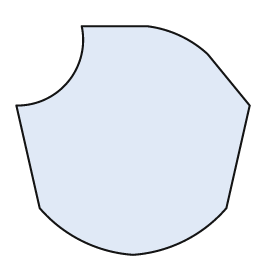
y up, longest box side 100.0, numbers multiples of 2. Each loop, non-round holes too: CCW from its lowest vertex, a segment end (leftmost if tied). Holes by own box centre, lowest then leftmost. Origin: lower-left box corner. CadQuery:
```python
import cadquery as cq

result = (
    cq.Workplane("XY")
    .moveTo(50.0, 0.0)
    .threePointArc((72.0, 6.0), (90.0, 20.0))
    .lineTo(100.0, 64.0)
    .lineTo(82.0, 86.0)
    .threePointArc((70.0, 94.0), (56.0, 98.0))
    .lineTo(28.0, 98.0)
    .threePointArc((22.0, 74.0), (0.0, 64.0))
    .lineTo(10.0, 20.0)
    .threePointArc((28.0, 6.0), (50.0, 0.0))
    .close()
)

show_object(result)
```